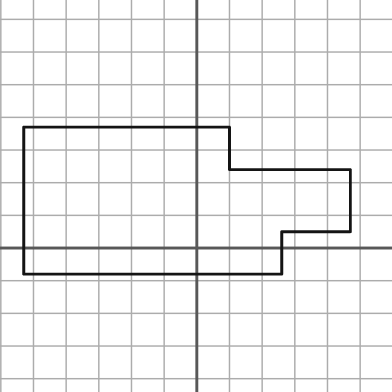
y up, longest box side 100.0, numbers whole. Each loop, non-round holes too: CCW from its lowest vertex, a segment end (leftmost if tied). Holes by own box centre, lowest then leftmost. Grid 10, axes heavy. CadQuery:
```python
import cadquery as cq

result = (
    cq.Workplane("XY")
    .moveTo(-53.0, -8.0)
    .lineTo(26.0, -8.0)
    .lineTo(26.0, 5.0)
    .lineTo(47.0, 5.0)
    .lineTo(47.0, 24.0)
    .lineTo(10.0, 24.0)
    .lineTo(10.0, 37.0)
    .lineTo(-53.0, 37.0)
    .close()
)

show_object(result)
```